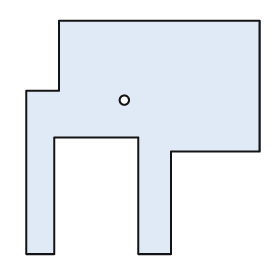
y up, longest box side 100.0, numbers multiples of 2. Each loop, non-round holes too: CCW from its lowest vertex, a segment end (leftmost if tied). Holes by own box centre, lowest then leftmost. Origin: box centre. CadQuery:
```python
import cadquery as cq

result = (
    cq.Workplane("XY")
    .moveTo(-50.0, -50.0)
    .lineTo(-38.0, -50.0)
    .lineTo(-38.0, 0.0)
    .lineTo(-2.0, 0.0)
    .lineTo(-2.0, -50.0)
    .lineTo(12.0, -50.0)
    .lineTo(12.0, -6.0)
    .lineTo(50.0, -6.0)
    .lineTo(50.0, 50.0)
    .lineTo(-36.0, 50.0)
    .lineTo(-36.0, 20.0)
    .lineTo(-50.0, 20.0)
    .close()
    .moveTo(-8.0, 16.0)
    .circle(2.0)
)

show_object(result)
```